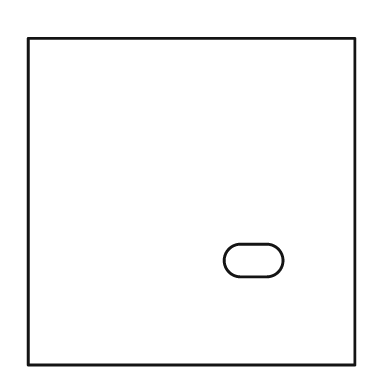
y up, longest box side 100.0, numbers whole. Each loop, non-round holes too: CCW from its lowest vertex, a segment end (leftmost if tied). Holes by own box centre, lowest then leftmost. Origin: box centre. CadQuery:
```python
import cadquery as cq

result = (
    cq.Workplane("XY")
    .moveTo(-50.0, -50.0)
    .lineTo(50.0, -50.0)
    .lineTo(50.0, 50.0)
    .lineTo(-50.0, 50.0)
    .close()
    .moveTo(15.0, -23.0)
    .lineTo(23.0, -23.0)
    .threePointArc((28.0, -18.0), (23.0, -13.0))
    .lineTo(15.0, -13.0)
    .threePointArc((10.0, -18.0), (15.0, -23.0))
    .close()
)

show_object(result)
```